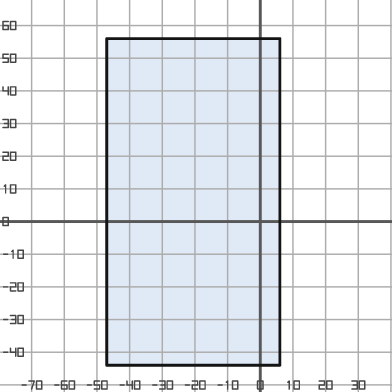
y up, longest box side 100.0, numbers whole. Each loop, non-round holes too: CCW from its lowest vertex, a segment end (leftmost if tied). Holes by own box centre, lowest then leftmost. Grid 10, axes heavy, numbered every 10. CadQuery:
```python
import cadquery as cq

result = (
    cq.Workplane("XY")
    .moveTo(-47.0, -44.0)
    .lineTo(6.0, -44.0)
    .lineTo(6.0, 56.0)
    .lineTo(-47.0, 56.0)
    .close()
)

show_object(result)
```